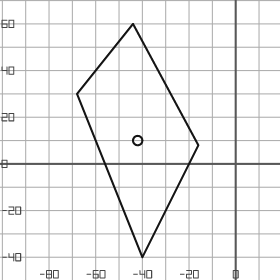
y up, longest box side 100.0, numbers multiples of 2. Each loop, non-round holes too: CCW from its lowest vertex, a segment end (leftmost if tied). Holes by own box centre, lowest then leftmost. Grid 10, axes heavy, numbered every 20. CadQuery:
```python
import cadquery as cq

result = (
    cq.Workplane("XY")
    .moveTo(-40.0, -40.0)
    .lineTo(-16.0, 8.0)
    .lineTo(-44.0, 60.0)
    .lineTo(-68.0, 30.0)
    .close()
    .moveTo(-42.0, 10.0)
    .circle(2.0)
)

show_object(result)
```